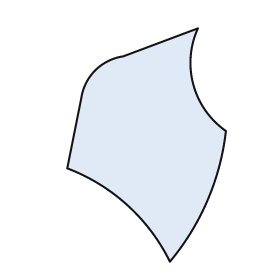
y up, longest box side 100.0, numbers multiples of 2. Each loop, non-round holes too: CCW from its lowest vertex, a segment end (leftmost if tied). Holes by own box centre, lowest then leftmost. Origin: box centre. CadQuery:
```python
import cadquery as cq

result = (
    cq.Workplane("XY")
    .moveTo(10.0, -50.0)
    .threePointArc((26.0, -24.0), (34.0, 6.0))
    .threePointArc((20.0, 26.0), (22.0, 50.0))
    .lineTo(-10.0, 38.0)
    .threePointArc((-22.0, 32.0), (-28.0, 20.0))
    .lineTo(-34.0, -10.0)
    .threePointArc((-8.0, -26.0), (10.0, -50.0))
    .close()
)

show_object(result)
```